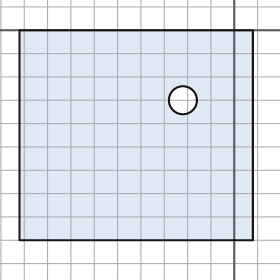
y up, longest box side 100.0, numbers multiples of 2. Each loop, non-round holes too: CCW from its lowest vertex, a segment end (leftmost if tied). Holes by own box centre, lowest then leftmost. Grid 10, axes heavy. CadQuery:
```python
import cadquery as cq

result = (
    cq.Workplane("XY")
    .moveTo(-92.0, -90.0)
    .lineTo(8.0, -90.0)
    .lineTo(8.0, 0.0)
    .lineTo(-92.0, 0.0)
    .close()
    .moveTo(-22.0, -30.0)
    .circle(6.0)
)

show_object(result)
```